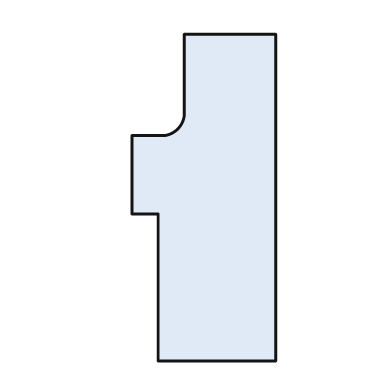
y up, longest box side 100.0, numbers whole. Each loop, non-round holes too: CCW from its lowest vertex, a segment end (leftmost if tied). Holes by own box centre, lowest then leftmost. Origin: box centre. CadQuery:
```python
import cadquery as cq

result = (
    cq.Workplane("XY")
    .moveTo(-14.0, -50.0)
    .lineTo(22.0, -50.0)
    .lineTo(22.0, 50.0)
    .lineTo(-6.0, 50.0)
    .lineTo(-6.0, 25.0)
    .threePointArc((-8.0, 21.0), (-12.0, 19.0))
    .lineTo(-22.0, 19.0)
    .lineTo(-22.0, -5.0)
    .lineTo(-14.0, -5.0)
    .close()
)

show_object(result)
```